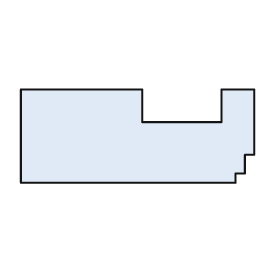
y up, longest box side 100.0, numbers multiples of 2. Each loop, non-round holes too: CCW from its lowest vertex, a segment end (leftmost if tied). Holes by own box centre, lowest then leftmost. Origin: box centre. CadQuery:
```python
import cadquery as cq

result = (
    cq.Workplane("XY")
    .moveTo(-50.0, -20.0)
    .lineTo(42.0, -20.0)
    .lineTo(42.0, -16.0)
    .lineTo(46.0, -16.0)
    .lineTo(46.0, -8.0)
    .lineTo(50.0, -8.0)
    .lineTo(50.0, 20.0)
    .lineTo(36.0, 20.0)
    .lineTo(36.0, 6.0)
    .lineTo(2.0, 6.0)
    .lineTo(2.0, 20.0)
    .lineTo(-50.0, 20.0)
    .close()
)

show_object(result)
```